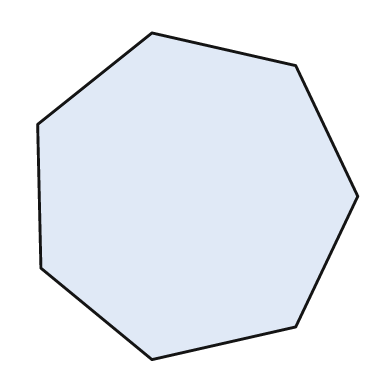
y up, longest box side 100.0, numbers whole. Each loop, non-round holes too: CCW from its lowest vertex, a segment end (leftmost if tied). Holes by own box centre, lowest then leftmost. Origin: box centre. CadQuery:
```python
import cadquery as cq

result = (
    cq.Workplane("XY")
    .moveTo(-14.0, -50.0)
    .lineTo(30.0, -40.0)
    .lineTo(49.0, 0.0)
    .lineTo(30.0, 40.0)
    .lineTo(-14.0, 50.0)
    .lineTo(-49.0, 22.0)
    .lineTo(-48.0, -22.0)
    .close()
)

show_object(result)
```